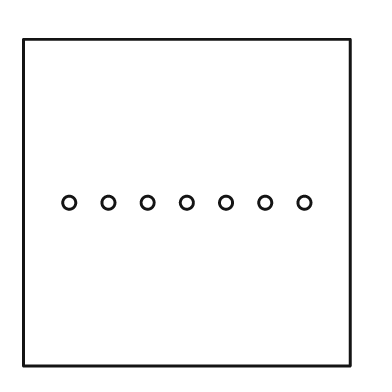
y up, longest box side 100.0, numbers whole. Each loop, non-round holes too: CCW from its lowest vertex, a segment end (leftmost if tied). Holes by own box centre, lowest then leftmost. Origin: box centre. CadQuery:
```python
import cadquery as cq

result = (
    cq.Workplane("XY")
    .moveTo(-50.0, -50.0)
    .lineTo(50.0, -50.0)
    .lineTo(50.0, 50.0)
    .lineTo(-50.0, 50.0)
    .close()
    .moveTo(-36.0, 0.0)
    .circle(2.0)
    .moveTo(-24.0, 0.0)
    .circle(2.0)
    .moveTo(-12.0, 0.0)
    .circle(2.0)
    .moveTo(0.0, 0.0)
    .circle(2.0)
    .moveTo(12.0, 0.0)
    .circle(2.0)
    .moveTo(24.0, 0.0)
    .circle(2.0)
    .moveTo(36.0, 0.0)
    .circle(2.0)
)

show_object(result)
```